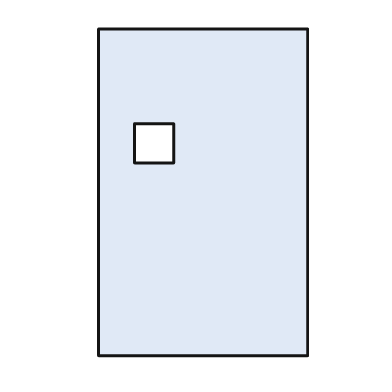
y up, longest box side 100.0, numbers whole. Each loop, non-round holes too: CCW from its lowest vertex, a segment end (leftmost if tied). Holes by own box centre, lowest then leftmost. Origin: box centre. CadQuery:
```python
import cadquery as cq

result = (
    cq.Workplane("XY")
    .moveTo(-32.0, -50.0)
    .lineTo(32.0, -50.0)
    .lineTo(32.0, 50.0)
    .lineTo(-32.0, 50.0)
    .close()
    .moveTo(-21.0, 9.0)
    .lineTo(-9.0, 9.0)
    .lineTo(-9.0, 21.0)
    .lineTo(-21.0, 21.0)
    .close()
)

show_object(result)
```